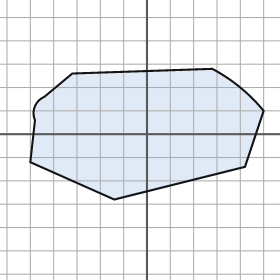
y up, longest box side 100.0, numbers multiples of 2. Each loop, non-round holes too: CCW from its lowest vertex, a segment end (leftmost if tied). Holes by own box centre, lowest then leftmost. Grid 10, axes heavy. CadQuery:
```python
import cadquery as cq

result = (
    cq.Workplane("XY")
    .moveTo(-14.0, -28.0)
    .lineTo(42.0, -14.0)
    .lineTo(50.0, 10.0)
    .threePointArc((40.0, 20.0), (28.0, 28.0))
    .lineTo(-32.0, 26.0)
    .lineTo(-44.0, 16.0)
    .threePointArc((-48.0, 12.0), (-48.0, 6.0))
    .lineTo(-50.0, -12.0)
    .close()
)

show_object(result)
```